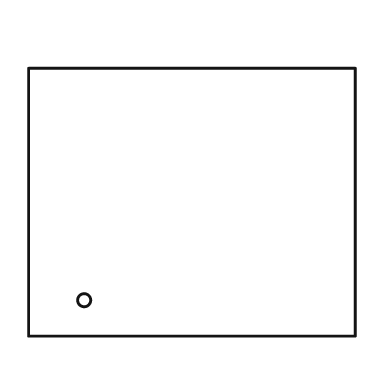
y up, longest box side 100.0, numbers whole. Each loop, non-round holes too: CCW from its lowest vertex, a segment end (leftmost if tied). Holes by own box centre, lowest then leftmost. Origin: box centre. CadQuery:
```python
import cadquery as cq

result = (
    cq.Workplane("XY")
    .moveTo(-50.0, -41.0)
    .lineTo(50.0, -41.0)
    .lineTo(50.0, 41.0)
    .lineTo(-50.0, 41.0)
    .close()
    .moveTo(-33.0, -30.0)
    .circle(2.0)
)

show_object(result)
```